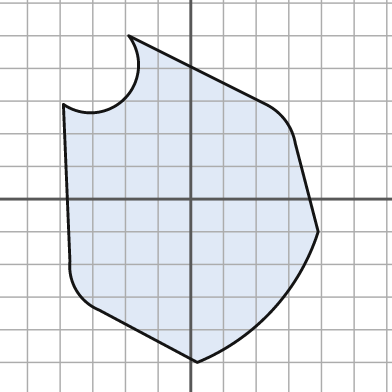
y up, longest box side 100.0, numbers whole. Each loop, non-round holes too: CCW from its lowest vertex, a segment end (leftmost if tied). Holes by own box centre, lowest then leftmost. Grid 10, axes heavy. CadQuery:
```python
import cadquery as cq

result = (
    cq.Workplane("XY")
    .moveTo(2.0, -50.0)
    .threePointArc((25.0, -34.0), (39.0, -10.0))
    .lineTo(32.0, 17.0)
    .threePointArc((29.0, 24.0), (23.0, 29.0))
    .lineTo(-19.0, 50.0)
    .threePointArc((-20.0, 31.0), (-39.0, 29.0))
    .lineTo(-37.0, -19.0)
    .threePointArc((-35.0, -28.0), (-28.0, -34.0))
    .close()
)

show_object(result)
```